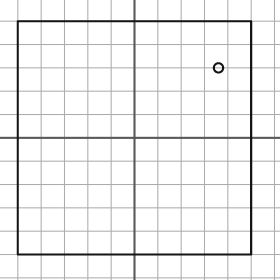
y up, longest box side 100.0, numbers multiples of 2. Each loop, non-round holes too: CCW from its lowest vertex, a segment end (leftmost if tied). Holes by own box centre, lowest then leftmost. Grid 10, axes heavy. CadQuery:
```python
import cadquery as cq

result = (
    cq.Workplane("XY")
    .moveTo(-50.0, -50.0)
    .lineTo(50.0, -50.0)
    .lineTo(50.0, 50.0)
    .lineTo(-50.0, 50.0)
    .close()
    .moveTo(36.0, 30.0)
    .circle(2.0)
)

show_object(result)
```